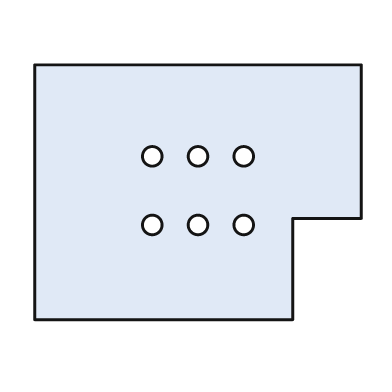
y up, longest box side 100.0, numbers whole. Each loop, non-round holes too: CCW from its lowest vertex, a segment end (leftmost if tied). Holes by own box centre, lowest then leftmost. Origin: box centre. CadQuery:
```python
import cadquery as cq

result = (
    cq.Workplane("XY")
    .moveTo(-50.0, -39.0)
    .lineTo(29.0, -39.0)
    .lineTo(29.0, -8.0)
    .lineTo(50.0, -8.0)
    .lineTo(50.0, 39.0)
    .lineTo(-50.0, 39.0)
    .close()
    .moveTo(-14.0, -10.0)
    .circle(3.0)
    .moveTo(0.0, -10.0)
    .circle(3.0)
    .moveTo(14.0, -10.0)
    .circle(3.0)
    .moveTo(-14.0, 11.0)
    .circle(3.0)
    .moveTo(0.0, 11.0)
    .circle(3.0)
    .moveTo(14.0, 11.0)
    .circle(3.0)
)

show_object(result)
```